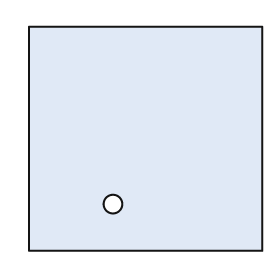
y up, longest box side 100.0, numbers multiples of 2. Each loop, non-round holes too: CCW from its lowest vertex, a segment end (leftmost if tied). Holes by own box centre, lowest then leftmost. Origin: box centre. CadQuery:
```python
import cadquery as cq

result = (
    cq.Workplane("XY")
    .moveTo(-50.0, -48.0)
    .lineTo(50.0, -48.0)
    .lineTo(50.0, 48.0)
    .lineTo(-50.0, 48.0)
    .close()
    .moveTo(-14.0, -28.0)
    .circle(4.0)
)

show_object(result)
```